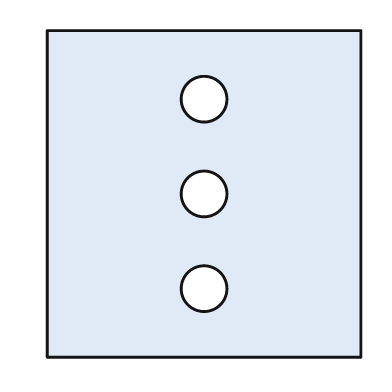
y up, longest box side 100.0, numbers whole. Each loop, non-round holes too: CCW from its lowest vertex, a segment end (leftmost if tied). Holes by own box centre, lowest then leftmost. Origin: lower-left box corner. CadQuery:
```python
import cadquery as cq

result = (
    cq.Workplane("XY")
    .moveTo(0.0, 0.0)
    .lineTo(96.0, 0.0)
    .lineTo(96.0, 100.0)
    .lineTo(0.0, 100.0)
    .close()
    .moveTo(48.0, 21.0)
    .circle(7.0)
    .moveTo(48.0, 50.0)
    .circle(7.0)
    .moveTo(48.0, 79.0)
    .circle(7.0)
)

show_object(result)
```